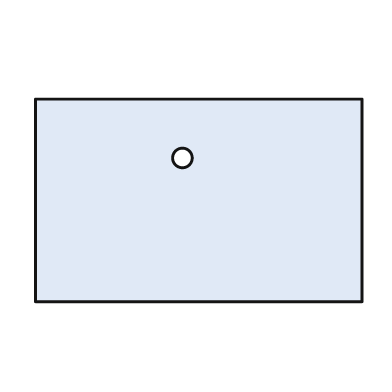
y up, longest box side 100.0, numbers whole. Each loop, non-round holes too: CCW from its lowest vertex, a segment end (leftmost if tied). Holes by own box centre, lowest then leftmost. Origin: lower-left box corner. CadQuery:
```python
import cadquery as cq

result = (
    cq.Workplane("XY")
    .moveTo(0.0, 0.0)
    .lineTo(100.0, 0.0)
    .lineTo(100.0, 62.0)
    .lineTo(0.0, 62.0)
    .close()
    .moveTo(45.0, 44.0)
    .circle(3.0)
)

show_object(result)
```